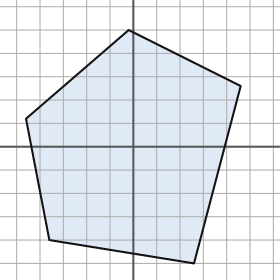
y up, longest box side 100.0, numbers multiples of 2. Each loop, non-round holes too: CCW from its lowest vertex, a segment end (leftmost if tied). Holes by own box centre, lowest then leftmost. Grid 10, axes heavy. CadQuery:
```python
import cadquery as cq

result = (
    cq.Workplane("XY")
    .moveTo(26.0, -50.0)
    .lineTo(46.0, 26.0)
    .lineTo(-2.0, 50.0)
    .lineTo(-46.0, 12.0)
    .lineTo(-36.0, -40.0)
    .close()
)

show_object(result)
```